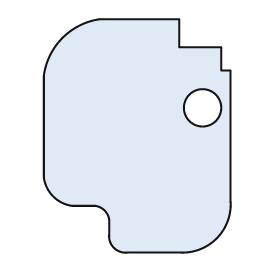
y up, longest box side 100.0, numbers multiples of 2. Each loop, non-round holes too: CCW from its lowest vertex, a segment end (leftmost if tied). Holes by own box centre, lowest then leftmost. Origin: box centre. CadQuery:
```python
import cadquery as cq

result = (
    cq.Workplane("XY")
    .moveTo(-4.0, -50.0)
    .lineTo(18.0, -50.0)
    .threePointArc((34.0, -44.0), (40.0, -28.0))
    .lineTo(40.0, 28.0)
    .lineTo(36.0, 28.0)
    .lineTo(36.0, 38.0)
    .lineTo(18.0, 38.0)
    .lineTo(18.0, 50.0)
    .lineTo(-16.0, 50.0)
    .threePointArc((-32.0, 42.0), (-40.0, 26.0))
    .lineTo(-40.0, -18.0)
    .threePointArc((-36.0, -26.0), (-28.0, -30.0))
    .lineTo(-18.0, -30.0)
    .threePointArc((-14.0, -32.0), (-12.0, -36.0))
    .lineTo(-12.0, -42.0)
    .threePointArc((-10.0, -48.0), (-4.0, -50.0))
    .close()
    .moveTo(28.0, 12.0)
    .circle(8.0)
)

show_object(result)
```